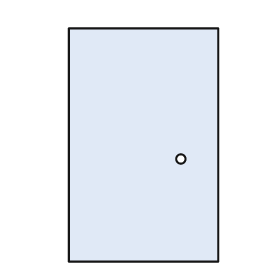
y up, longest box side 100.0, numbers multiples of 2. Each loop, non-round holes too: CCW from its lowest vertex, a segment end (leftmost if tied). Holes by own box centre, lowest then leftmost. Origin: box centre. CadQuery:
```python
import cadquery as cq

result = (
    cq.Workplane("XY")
    .moveTo(-32.0, -50.0)
    .lineTo(32.0, -50.0)
    .lineTo(32.0, 50.0)
    .lineTo(-32.0, 50.0)
    .close()
    .moveTo(16.0, -6.0)
    .circle(2.0)
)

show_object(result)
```